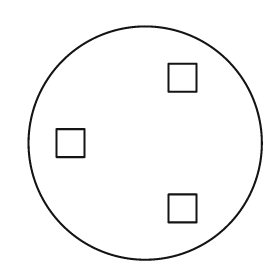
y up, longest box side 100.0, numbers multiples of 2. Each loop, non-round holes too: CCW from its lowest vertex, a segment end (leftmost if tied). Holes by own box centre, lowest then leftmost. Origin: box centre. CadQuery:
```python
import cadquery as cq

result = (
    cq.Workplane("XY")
    .moveTo(0.0, 0.0)
    .circle(50.0)
    .moveTo(10.0, -34.0)
    .lineTo(22.0, -34.0)
    .lineTo(22.0, -22.0)
    .lineTo(10.0, -22.0)
    .close()
    .moveTo(-38.0, -6.0)
    .lineTo(-26.0, -6.0)
    .lineTo(-26.0, 6.0)
    .lineTo(-38.0, 6.0)
    .close()
    .moveTo(10.0, 22.0)
    .lineTo(22.0, 22.0)
    .lineTo(22.0, 34.0)
    .lineTo(10.0, 34.0)
    .close()
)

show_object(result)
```